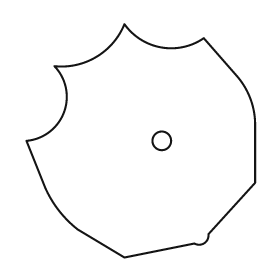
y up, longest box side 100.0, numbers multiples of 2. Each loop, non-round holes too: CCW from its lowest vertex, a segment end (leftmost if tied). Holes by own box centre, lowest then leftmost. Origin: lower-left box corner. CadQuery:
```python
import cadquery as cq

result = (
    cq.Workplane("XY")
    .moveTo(42.0, 0.0)
    .lineTo(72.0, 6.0)
    .threePointArc((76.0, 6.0), (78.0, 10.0))
    .lineTo(98.0, 32.0)
    .lineTo(98.0, 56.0)
    .threePointArc((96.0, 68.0), (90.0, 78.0))
    .lineTo(76.0, 94.0)
    .threePointArc((58.0, 90.0), (42.0, 100.0))
    .threePointArc((30.0, 86.0), (12.0, 82.0))
    .threePointArc((16.0, 62.0), (0.0, 50.0))
    .lineTo(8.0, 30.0)
    .threePointArc((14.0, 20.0), (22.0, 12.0))
    .close()
    .moveTo(58.0, 50.0)
    .circle(4.0)
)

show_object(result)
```